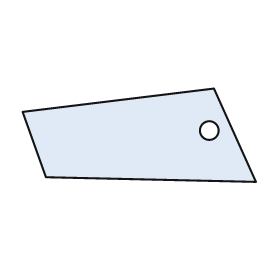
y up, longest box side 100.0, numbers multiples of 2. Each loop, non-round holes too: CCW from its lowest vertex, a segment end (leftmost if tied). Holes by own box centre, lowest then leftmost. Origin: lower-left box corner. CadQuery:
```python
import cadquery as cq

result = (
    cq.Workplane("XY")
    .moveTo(100.0, 0.0)
    .lineTo(82.0, 40.0)
    .lineTo(0.0, 30.0)
    .lineTo(10.0, 2.0)
    .close()
    .moveTo(80.0, 22.0)
    .circle(4.0)
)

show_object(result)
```